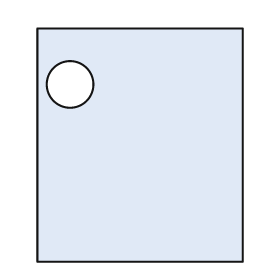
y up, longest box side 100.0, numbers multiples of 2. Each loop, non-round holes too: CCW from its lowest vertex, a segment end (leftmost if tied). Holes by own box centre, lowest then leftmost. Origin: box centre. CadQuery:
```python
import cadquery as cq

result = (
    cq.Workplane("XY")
    .moveTo(-44.0, -50.0)
    .lineTo(44.0, -50.0)
    .lineTo(44.0, 50.0)
    .lineTo(-44.0, 50.0)
    .close()
    .moveTo(-30.0, 26.0)
    .circle(10.0)
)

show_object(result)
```